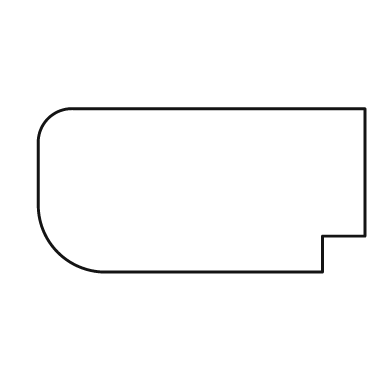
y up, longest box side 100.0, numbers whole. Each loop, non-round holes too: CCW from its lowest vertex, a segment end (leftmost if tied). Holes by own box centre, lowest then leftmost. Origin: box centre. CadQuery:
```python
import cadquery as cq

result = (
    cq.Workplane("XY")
    .moveTo(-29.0, -25.0)
    .lineTo(37.0, -25.0)
    .lineTo(37.0, -14.0)
    .lineTo(50.0, -14.0)
    .lineTo(50.0, 25.0)
    .lineTo(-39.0, 25.0)
    .threePointArc((-47.0, 22.0), (-50.0, 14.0))
    .lineTo(-50.0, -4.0)
    .threePointArc((-44.0, -19.0), (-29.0, -25.0))
    .close()
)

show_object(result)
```